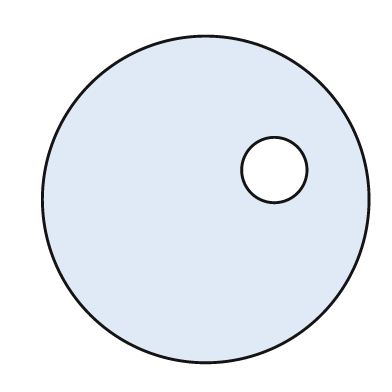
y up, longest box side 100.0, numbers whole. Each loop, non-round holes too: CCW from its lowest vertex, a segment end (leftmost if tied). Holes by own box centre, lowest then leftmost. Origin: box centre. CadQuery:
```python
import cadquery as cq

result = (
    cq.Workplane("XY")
    .moveTo(0.0, 0.0)
    .circle(50.0)
    .moveTo(21.0, 9.0)
    .circle(10.0)
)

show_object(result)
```